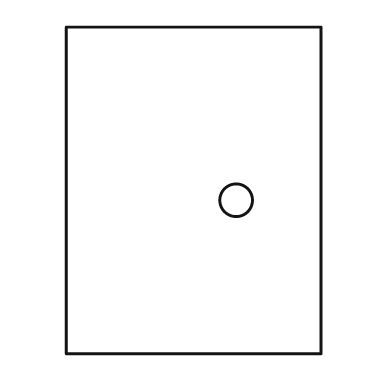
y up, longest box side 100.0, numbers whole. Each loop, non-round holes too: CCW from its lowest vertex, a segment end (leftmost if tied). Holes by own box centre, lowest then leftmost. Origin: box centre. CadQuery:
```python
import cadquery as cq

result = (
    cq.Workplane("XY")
    .moveTo(-39.0, -50.0)
    .lineTo(39.0, -50.0)
    .lineTo(39.0, 50.0)
    .lineTo(-39.0, 50.0)
    .close()
    .moveTo(13.0, -3.0)
    .circle(5.0)
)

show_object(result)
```